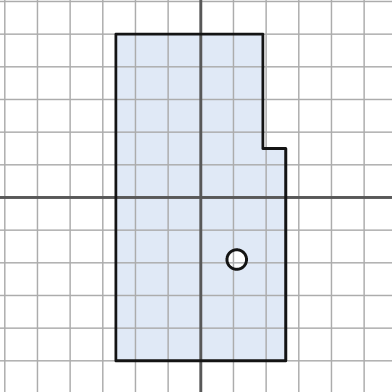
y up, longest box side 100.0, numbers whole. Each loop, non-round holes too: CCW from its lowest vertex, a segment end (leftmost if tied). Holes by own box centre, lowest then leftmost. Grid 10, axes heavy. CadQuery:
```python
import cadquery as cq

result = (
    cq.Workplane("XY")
    .moveTo(-26.0, -50.0)
    .lineTo(26.0, -50.0)
    .lineTo(26.0, 15.0)
    .lineTo(19.0, 15.0)
    .lineTo(19.0, 50.0)
    .lineTo(-26.0, 50.0)
    .close()
    .moveTo(11.0, -19.0)
    .circle(3.0)
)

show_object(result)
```